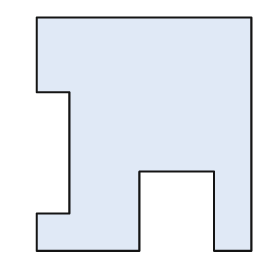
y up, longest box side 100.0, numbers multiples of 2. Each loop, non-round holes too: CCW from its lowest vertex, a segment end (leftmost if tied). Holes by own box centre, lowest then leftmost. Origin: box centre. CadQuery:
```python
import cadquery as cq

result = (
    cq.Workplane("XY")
    .moveTo(-46.0, -50.0)
    .lineTo(-2.0, -50.0)
    .lineTo(-2.0, -16.0)
    .lineTo(30.0, -16.0)
    .lineTo(30.0, -50.0)
    .lineTo(46.0, -50.0)
    .lineTo(46.0, 50.0)
    .lineTo(-46.0, 50.0)
    .lineTo(-46.0, 18.0)
    .lineTo(-32.0, 18.0)
    .lineTo(-32.0, -34.0)
    .lineTo(-46.0, -34.0)
    .close()
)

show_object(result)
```